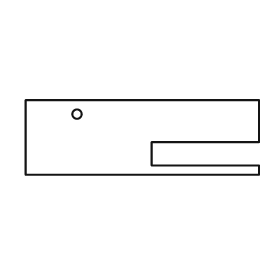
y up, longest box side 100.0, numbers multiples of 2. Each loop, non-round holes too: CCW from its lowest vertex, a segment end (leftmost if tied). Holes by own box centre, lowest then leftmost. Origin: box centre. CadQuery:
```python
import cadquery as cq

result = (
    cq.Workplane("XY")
    .moveTo(-50.0, -16.0)
    .lineTo(50.0, -16.0)
    .lineTo(50.0, -12.0)
    .lineTo(4.0, -12.0)
    .lineTo(4.0, -2.0)
    .lineTo(50.0, -2.0)
    .lineTo(50.0, 16.0)
    .lineTo(-50.0, 16.0)
    .close()
    .moveTo(-28.0, 10.0)
    .circle(2.0)
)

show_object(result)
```